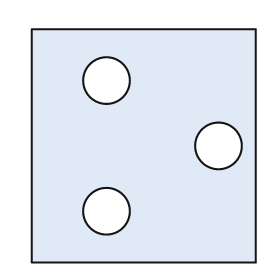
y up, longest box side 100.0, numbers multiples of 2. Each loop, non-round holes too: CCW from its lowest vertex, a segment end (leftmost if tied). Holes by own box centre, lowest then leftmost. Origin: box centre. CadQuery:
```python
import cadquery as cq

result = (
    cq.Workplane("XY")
    .moveTo(-48.0, -50.0)
    .lineTo(48.0, -50.0)
    .lineTo(48.0, 50.0)
    .lineTo(-48.0, 50.0)
    .close()
    .moveTo(-16.0, -28.0)
    .circle(10.0)
    .moveTo(32.0, 0.0)
    .circle(10.0)
    .moveTo(-16.0, 28.0)
    .circle(10.0)
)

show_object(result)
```